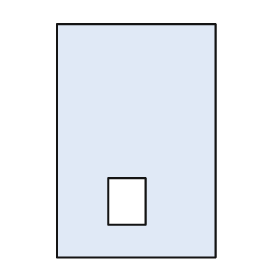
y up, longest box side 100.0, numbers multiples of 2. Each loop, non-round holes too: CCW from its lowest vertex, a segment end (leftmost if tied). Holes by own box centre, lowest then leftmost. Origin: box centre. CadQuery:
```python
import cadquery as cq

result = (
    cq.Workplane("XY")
    .moveTo(-34.0, -50.0)
    .lineTo(34.0, -50.0)
    .lineTo(34.0, 50.0)
    .lineTo(-34.0, 50.0)
    .close()
    .moveTo(-12.0, -36.0)
    .lineTo(4.0, -36.0)
    .lineTo(4.0, -16.0)
    .lineTo(-12.0, -16.0)
    .close()
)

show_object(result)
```